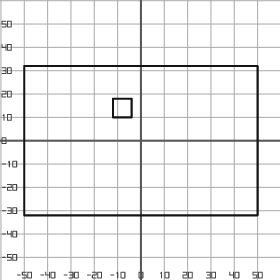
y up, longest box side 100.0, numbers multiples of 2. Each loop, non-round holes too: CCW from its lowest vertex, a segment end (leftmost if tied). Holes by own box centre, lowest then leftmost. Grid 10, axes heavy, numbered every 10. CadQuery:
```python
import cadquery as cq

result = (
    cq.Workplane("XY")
    .moveTo(-50.0, -32.0)
    .lineTo(50.0, -32.0)
    .lineTo(50.0, 32.0)
    .lineTo(-50.0, 32.0)
    .close()
    .moveTo(-12.0, 10.0)
    .lineTo(-4.0, 10.0)
    .lineTo(-4.0, 18.0)
    .lineTo(-12.0, 18.0)
    .close()
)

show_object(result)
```